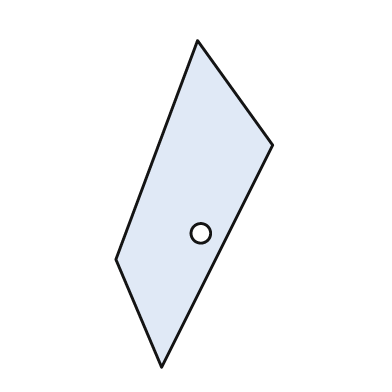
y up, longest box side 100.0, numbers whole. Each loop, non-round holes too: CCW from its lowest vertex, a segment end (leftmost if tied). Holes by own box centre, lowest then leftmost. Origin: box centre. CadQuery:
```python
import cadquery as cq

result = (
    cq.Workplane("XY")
    .moveTo(-10.0, -50.0)
    .lineTo(24.0, 18.0)
    .lineTo(1.0, 50.0)
    .lineTo(-24.0, -17.0)
    .close()
    .moveTo(2.0, -9.0)
    .circle(3.0)
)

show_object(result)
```